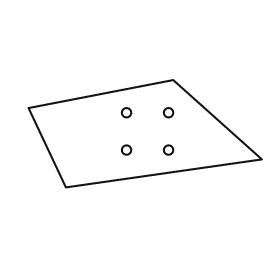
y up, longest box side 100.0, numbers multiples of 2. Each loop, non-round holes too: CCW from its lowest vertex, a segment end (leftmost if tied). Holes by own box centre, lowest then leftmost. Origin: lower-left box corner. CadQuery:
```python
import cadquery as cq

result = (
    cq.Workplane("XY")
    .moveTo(16.0, 0.0)
    .lineTo(100.0, 12.0)
    .lineTo(62.0, 46.0)
    .lineTo(0.0, 34.0)
    .close()
    .moveTo(42.0, 16.0)
    .circle(2.0)
    .moveTo(60.0, 16.0)
    .circle(2.0)
    .moveTo(42.0, 32.0)
    .circle(2.0)
    .moveTo(60.0, 32.0)
    .circle(2.0)
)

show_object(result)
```